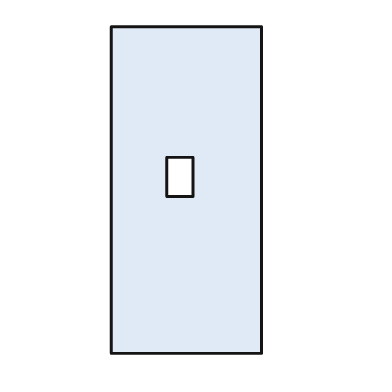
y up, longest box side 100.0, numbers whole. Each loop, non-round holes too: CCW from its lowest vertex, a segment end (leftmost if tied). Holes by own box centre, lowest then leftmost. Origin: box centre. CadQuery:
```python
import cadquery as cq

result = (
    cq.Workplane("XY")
    .moveTo(-23.0, -50.0)
    .lineTo(23.0, -50.0)
    .lineTo(23.0, 50.0)
    .lineTo(-23.0, 50.0)
    .close()
    .moveTo(-6.0, -2.0)
    .lineTo(2.0, -2.0)
    .lineTo(2.0, 10.0)
    .lineTo(-6.0, 10.0)
    .close()
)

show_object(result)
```